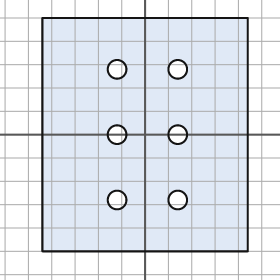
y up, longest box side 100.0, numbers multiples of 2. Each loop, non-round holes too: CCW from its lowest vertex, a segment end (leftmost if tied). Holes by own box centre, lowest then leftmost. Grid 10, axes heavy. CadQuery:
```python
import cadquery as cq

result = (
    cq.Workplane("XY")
    .moveTo(-44.0, -50.0)
    .lineTo(44.0, -50.0)
    .lineTo(44.0, 50.0)
    .lineTo(-44.0, 50.0)
    .close()
    .moveTo(-12.0, -28.0)
    .circle(4.0)
    .moveTo(14.0, -28.0)
    .circle(4.0)
    .moveTo(-12.0, 0.0)
    .circle(4.0)
    .moveTo(14.0, 0.0)
    .circle(4.0)
    .moveTo(-12.0, 28.0)
    .circle(4.0)
    .moveTo(14.0, 28.0)
    .circle(4.0)
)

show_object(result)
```